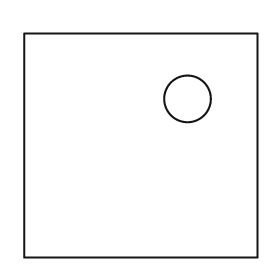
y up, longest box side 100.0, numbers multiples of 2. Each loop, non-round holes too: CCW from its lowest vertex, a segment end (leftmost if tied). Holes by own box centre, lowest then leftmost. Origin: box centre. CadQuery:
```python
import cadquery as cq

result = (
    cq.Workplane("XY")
    .moveTo(-50.0, -48.0)
    .lineTo(50.0, -48.0)
    .lineTo(50.0, 48.0)
    .lineTo(-50.0, 48.0)
    .close()
    .moveTo(20.0, 20.0)
    .circle(10.0)
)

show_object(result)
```